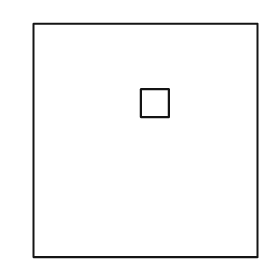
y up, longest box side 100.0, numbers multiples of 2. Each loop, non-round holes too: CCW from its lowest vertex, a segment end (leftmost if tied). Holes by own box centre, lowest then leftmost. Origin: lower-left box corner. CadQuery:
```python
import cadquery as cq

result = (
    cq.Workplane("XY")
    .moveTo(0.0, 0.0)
    .lineTo(96.0, 0.0)
    .lineTo(96.0, 100.0)
    .lineTo(0.0, 100.0)
    .close()
    .moveTo(46.0, 60.0)
    .lineTo(58.0, 60.0)
    .lineTo(58.0, 72.0)
    .lineTo(46.0, 72.0)
    .close()
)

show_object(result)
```